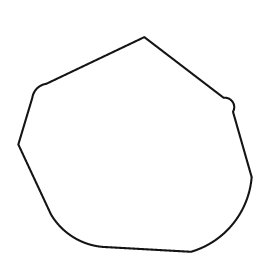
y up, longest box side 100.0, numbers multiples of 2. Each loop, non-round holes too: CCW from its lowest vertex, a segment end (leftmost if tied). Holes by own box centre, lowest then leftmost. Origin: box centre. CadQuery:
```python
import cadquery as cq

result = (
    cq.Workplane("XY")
    .moveTo(24.0, -46.0)
    .threePointArc((42.0, -34.0), (50.0, -14.0))
    .lineTo(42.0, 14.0)
    .threePointArc((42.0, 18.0), (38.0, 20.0))
    .lineTo(4.0, 46.0)
    .lineTo(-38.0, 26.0)
    .threePointArc((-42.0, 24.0), (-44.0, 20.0))
    .lineTo(-50.0, 0.0)
    .lineTo(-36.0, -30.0)
    .threePointArc((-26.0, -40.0), (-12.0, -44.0))
    .close()
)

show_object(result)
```